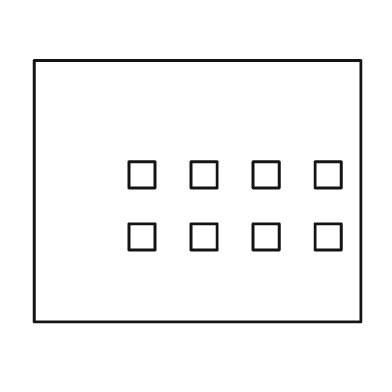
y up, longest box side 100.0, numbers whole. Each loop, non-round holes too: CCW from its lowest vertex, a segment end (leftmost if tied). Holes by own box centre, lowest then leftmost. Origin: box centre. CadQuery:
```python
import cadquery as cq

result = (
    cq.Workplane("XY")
    .moveTo(-50.0, -40.0)
    .lineTo(50.0, -40.0)
    .lineTo(50.0, 40.0)
    .lineTo(-50.0, 40.0)
    .close()
    .moveTo(-21.0, -18.0)
    .lineTo(-13.0, -18.0)
    .lineTo(-13.0, -10.0)
    .lineTo(-21.0, -10.0)
    .close()
    .moveTo(-2.0, -18.0)
    .lineTo(6.0, -18.0)
    .lineTo(6.0, -10.0)
    .lineTo(-2.0, -10.0)
    .close()
    .moveTo(17.0, -18.0)
    .lineTo(25.0, -18.0)
    .lineTo(25.0, -10.0)
    .lineTo(17.0, -10.0)
    .close()
    .moveTo(36.0, -18.0)
    .lineTo(44.0, -18.0)
    .lineTo(44.0, -10.0)
    .lineTo(36.0, -10.0)
    .close()
    .moveTo(-21.0, 1.0)
    .lineTo(-13.0, 1.0)
    .lineTo(-13.0, 9.0)
    .lineTo(-21.0, 9.0)
    .close()
    .moveTo(-2.0, 1.0)
    .lineTo(6.0, 1.0)
    .lineTo(6.0, 9.0)
    .lineTo(-2.0, 9.0)
    .close()
    .moveTo(17.0, 1.0)
    .lineTo(25.0, 1.0)
    .lineTo(25.0, 9.0)
    .lineTo(17.0, 9.0)
    .close()
    .moveTo(36.0, 1.0)
    .lineTo(44.0, 1.0)
    .lineTo(44.0, 9.0)
    .lineTo(36.0, 9.0)
    .close()
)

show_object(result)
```